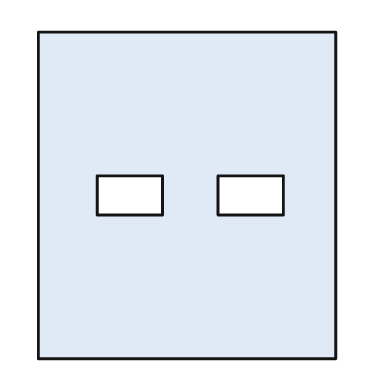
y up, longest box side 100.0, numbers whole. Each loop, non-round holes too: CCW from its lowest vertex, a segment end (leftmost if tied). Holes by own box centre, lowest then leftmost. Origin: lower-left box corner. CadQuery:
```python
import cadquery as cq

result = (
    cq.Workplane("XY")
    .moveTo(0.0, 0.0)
    .lineTo(91.0, 0.0)
    .lineTo(91.0, 100.0)
    .lineTo(0.0, 100.0)
    .close()
    .moveTo(18.0, 44.0)
    .lineTo(38.0, 44.0)
    .lineTo(38.0, 56.0)
    .lineTo(18.0, 56.0)
    .close()
    .moveTo(55.0, 44.0)
    .lineTo(75.0, 44.0)
    .lineTo(75.0, 56.0)
    .lineTo(55.0, 56.0)
    .close()
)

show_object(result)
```